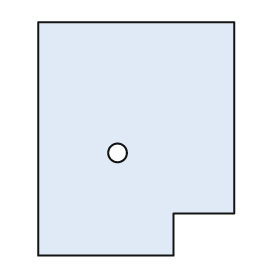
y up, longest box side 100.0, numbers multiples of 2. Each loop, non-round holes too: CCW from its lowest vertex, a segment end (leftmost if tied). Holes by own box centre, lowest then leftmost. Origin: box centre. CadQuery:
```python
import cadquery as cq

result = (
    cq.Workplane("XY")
    .moveTo(-42.0, -50.0)
    .lineTo(16.0, -50.0)
    .lineTo(16.0, -32.0)
    .lineTo(42.0, -32.0)
    .lineTo(42.0, 50.0)
    .lineTo(-42.0, 50.0)
    .close()
    .moveTo(-8.0, -6.0)
    .circle(4.0)
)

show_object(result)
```